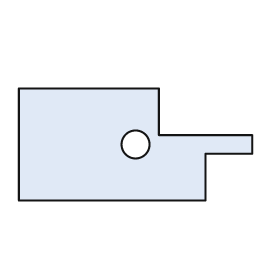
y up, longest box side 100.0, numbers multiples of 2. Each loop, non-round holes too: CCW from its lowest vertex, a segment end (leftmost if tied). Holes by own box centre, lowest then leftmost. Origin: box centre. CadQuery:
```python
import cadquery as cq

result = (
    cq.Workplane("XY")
    .moveTo(-50.0, -24.0)
    .lineTo(30.0, -24.0)
    .lineTo(30.0, -4.0)
    .lineTo(50.0, -4.0)
    .lineTo(50.0, 4.0)
    .lineTo(10.0, 4.0)
    .lineTo(10.0, 24.0)
    .lineTo(-50.0, 24.0)
    .close()
    .moveTo(0.0, 0.0)
    .circle(6.0)
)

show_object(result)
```